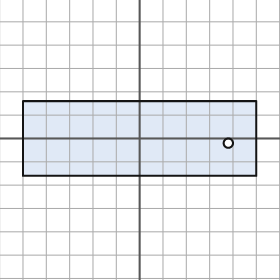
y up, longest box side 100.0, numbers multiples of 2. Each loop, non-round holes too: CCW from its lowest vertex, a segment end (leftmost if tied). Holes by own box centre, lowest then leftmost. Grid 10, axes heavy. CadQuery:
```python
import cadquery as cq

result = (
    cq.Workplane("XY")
    .moveTo(-50.0, -16.0)
    .lineTo(50.0, -16.0)
    .lineTo(50.0, 16.0)
    .lineTo(-50.0, 16.0)
    .close()
    .moveTo(38.0, -2.0)
    .circle(2.0)
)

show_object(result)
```